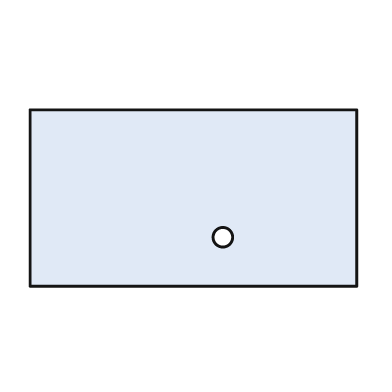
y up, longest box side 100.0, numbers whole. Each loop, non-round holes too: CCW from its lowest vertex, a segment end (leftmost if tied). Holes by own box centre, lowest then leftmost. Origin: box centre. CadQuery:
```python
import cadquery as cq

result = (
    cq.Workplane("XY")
    .moveTo(-50.0, -27.0)
    .lineTo(50.0, -27.0)
    .lineTo(50.0, 27.0)
    .lineTo(-50.0, 27.0)
    .close()
    .moveTo(9.0, -12.0)
    .circle(3.0)
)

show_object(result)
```